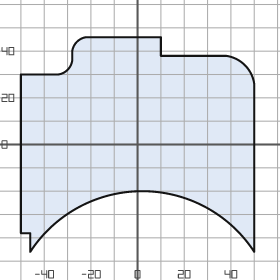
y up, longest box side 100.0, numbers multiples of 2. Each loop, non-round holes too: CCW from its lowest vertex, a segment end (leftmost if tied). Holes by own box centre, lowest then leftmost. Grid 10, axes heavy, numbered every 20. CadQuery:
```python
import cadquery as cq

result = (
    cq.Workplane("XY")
    .moveTo(-46.0, -46.0)
    .threePointArc((2.0, -20.0), (50.0, -46.0))
    .lineTo(50.0, 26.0)
    .threePointArc((46.0, 34.0), (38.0, 38.0))
    .lineTo(10.0, 38.0)
    .lineTo(10.0, 46.0)
    .lineTo(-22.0, 46.0)
    .threePointArc((-26.0, 44.0), (-28.0, 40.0))
    .lineTo(-28.0, 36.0)
    .threePointArc((-30.0, 32.0), (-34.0, 30.0))
    .lineTo(-50.0, 30.0)
    .lineTo(-50.0, -38.0)
    .lineTo(-46.0, -38.0)
    .close()
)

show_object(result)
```